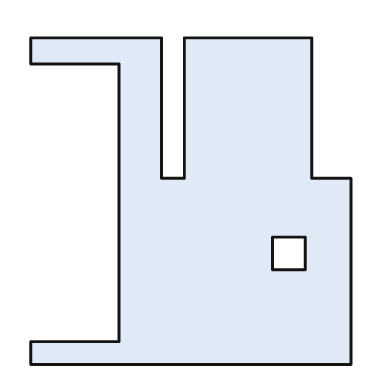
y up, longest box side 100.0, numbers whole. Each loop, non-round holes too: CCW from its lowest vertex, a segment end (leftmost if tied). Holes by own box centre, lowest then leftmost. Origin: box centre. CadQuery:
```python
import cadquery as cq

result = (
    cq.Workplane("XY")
    .moveTo(-49.0, -50.0)
    .lineTo(49.0, -50.0)
    .lineTo(49.0, 7.0)
    .lineTo(37.0, 7.0)
    .lineTo(37.0, 50.0)
    .lineTo(-2.0, 50.0)
    .lineTo(-2.0, 7.0)
    .lineTo(-9.0, 7.0)
    .lineTo(-9.0, 50.0)
    .lineTo(-49.0, 50.0)
    .lineTo(-49.0, 42.0)
    .lineTo(-22.0, 42.0)
    .lineTo(-22.0, -43.0)
    .lineTo(-49.0, -43.0)
    .close()
    .moveTo(25.0, -21.0)
    .lineTo(35.0, -21.0)
    .lineTo(35.0, -11.0)
    .lineTo(25.0, -11.0)
    .close()
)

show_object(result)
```